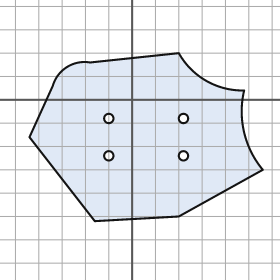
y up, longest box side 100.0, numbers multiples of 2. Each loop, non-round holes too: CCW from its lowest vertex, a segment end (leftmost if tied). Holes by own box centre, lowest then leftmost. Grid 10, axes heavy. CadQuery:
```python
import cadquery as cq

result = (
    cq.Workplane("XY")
    .moveTo(-16.0, -52.0)
    .lineTo(20.0, -50.0)
    .lineTo(56.0, -30.0)
    .threePointArc((48.0, -14.0), (48.0, 4.0))
    .threePointArc((32.0, 8.0), (20.0, 20.0))
    .lineTo(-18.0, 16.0)
    .threePointArc((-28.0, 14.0), (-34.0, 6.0))
    .lineTo(-44.0, -16.0)
    .close()
    .moveTo(-10.0, -24.0)
    .circle(2.0)
    .moveTo(22.0, -24.0)
    .circle(2.0)
    .moveTo(-10.0, -8.0)
    .circle(2.0)
    .moveTo(22.0, -8.0)
    .circle(2.0)
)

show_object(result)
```